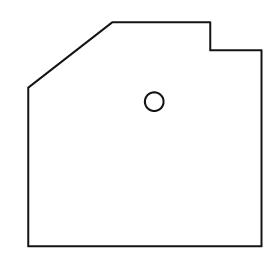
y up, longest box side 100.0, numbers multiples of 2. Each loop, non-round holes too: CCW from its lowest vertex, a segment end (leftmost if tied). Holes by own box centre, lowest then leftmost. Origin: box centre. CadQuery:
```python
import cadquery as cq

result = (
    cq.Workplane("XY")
    .moveTo(-50.0, -48.0)
    .lineTo(50.0, -48.0)
    .lineTo(50.0, 36.0)
    .lineTo(28.0, 36.0)
    .lineTo(28.0, 48.0)
    .lineTo(-14.0, 48.0)
    .lineTo(-50.0, 20.0)
    .close()
    .moveTo(4.0, 14.0)
    .circle(4.0)
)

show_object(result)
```